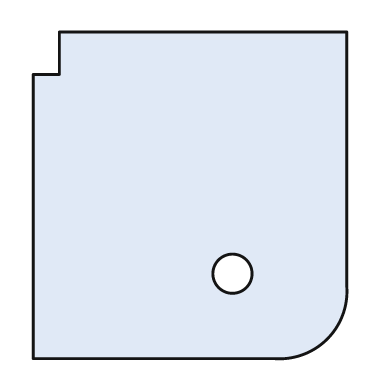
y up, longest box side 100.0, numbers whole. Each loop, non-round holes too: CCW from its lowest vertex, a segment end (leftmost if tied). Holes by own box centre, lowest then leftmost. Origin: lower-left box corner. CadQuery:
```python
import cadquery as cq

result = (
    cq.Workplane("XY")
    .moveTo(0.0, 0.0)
    .lineTo(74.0, 0.0)
    .threePointArc((90.0, 6.0), (96.0, 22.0))
    .lineTo(96.0, 100.0)
    .lineTo(8.0, 100.0)
    .lineTo(8.0, 87.0)
    .lineTo(0.0, 87.0)
    .close()
    .moveTo(61.0, 26.0)
    .circle(6.0)
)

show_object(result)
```